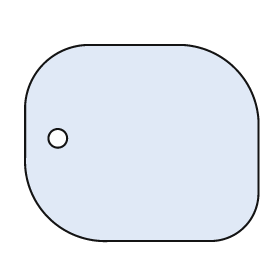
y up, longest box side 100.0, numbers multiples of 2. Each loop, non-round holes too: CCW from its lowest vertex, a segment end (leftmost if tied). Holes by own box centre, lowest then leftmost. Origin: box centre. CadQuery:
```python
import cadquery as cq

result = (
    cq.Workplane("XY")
    .moveTo(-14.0, -42.0)
    .lineTo(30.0, -42.0)
    .threePointArc((44.0, -36.0), (50.0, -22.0))
    .lineTo(50.0, 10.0)
    .threePointArc((40.0, 32.0), (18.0, 42.0))
    .lineTo(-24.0, 42.0)
    .threePointArc((-42.0, 34.0), (-50.0, 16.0))
    .lineTo(-50.0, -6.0)
    .threePointArc((-40.0, -32.0), (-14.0, -42.0))
    .close()
    .moveTo(-36.0, 2.0)
    .circle(4.0)
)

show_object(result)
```